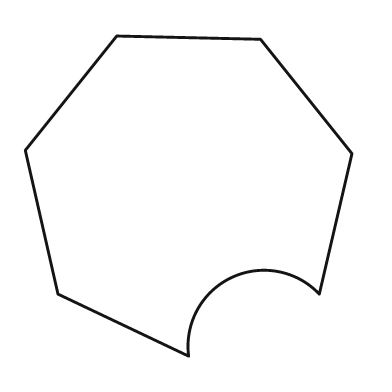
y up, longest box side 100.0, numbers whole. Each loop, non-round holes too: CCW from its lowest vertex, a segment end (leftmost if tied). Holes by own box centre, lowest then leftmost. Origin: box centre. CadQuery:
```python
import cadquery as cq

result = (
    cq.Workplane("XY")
    .moveTo(0.0, -49.0)
    .threePointArc((13.0, -25.0), (40.0, -30.0))
    .lineTo(50.0, 13.0)
    .lineTo(22.0, 48.0)
    .lineTo(-22.0, 49.0)
    .lineTo(-50.0, 14.0)
    .lineTo(-40.0, -30.0)
    .close()
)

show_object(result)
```